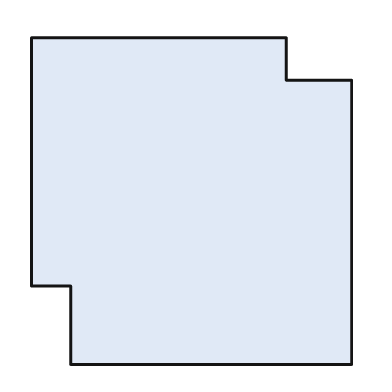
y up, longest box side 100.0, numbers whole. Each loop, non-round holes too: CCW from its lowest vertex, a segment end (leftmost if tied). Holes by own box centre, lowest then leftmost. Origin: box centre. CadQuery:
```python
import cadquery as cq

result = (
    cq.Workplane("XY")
    .moveTo(-37.0, -50.0)
    .lineTo(49.0, -50.0)
    .lineTo(49.0, 37.0)
    .lineTo(29.0, 37.0)
    .lineTo(29.0, 50.0)
    .lineTo(-49.0, 50.0)
    .lineTo(-49.0, -26.0)
    .lineTo(-37.0, -26.0)
    .close()
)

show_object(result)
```